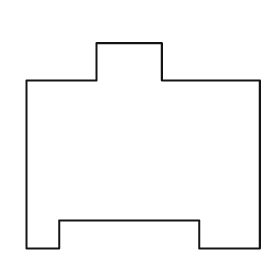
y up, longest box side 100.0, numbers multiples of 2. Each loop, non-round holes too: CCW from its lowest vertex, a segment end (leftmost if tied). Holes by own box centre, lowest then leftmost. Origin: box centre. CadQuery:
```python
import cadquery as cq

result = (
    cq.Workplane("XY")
    .moveTo(-50.0, -44.0)
    .lineTo(-36.0, -44.0)
    .lineTo(-36.0, -32.0)
    .lineTo(24.0, -32.0)
    .lineTo(24.0, -44.0)
    .lineTo(50.0, -44.0)
    .lineTo(50.0, 28.0)
    .lineTo(8.0, 28.0)
    .lineTo(8.0, 44.0)
    .lineTo(-20.0, 44.0)
    .lineTo(-20.0, 28.0)
    .lineTo(-50.0, 28.0)
    .close()
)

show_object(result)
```